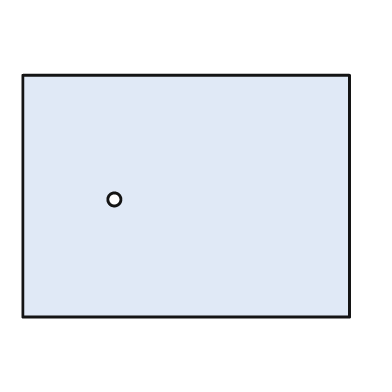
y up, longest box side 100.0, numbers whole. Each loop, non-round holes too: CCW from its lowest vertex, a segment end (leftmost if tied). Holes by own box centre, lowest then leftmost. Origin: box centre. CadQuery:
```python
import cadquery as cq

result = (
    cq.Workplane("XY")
    .moveTo(-50.0, -37.0)
    .lineTo(50.0, -37.0)
    .lineTo(50.0, 37.0)
    .lineTo(-50.0, 37.0)
    .close()
    .moveTo(-22.0, -1.0)
    .circle(2.0)
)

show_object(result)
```